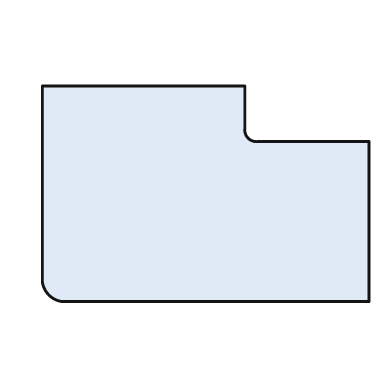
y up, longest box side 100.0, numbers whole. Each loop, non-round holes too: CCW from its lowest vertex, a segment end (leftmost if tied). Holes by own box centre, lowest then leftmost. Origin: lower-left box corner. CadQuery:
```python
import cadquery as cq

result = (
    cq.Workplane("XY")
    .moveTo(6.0, 0.0)
    .lineTo(100.0, 0.0)
    .lineTo(100.0, 49.0)
    .lineTo(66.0, 49.0)
    .threePointArc((63.0, 50.0), (62.0, 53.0))
    .lineTo(62.0, 66.0)
    .lineTo(0.0, 66.0)
    .lineTo(0.0, 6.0)
    .threePointArc((2.0, 2.0), (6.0, 0.0))
    .close()
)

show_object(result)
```